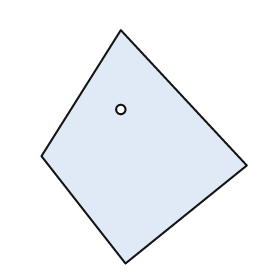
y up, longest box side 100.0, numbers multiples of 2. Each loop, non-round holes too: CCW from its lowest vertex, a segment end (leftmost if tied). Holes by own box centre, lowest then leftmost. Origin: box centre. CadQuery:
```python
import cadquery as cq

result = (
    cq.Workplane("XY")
    .moveTo(-8.0, -50.0)
    .lineTo(44.0, -8.0)
    .lineTo(-10.0, 50.0)
    .lineTo(-44.0, -4.0)
    .close()
    .moveTo(-10.0, 16.0)
    .circle(2.0)
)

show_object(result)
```